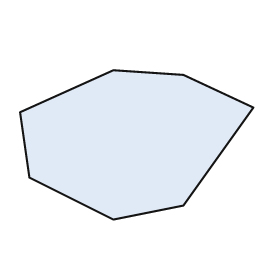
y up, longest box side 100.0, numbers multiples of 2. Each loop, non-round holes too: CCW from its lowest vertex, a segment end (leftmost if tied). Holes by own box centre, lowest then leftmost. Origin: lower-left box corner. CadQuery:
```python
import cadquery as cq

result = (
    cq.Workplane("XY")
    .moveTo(40.0, 0.0)
    .lineTo(70.0, 6.0)
    .lineTo(100.0, 48.0)
    .lineTo(70.0, 62.0)
    .lineTo(40.0, 64.0)
    .lineTo(0.0, 46.0)
    .lineTo(4.0, 18.0)
    .close()
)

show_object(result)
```